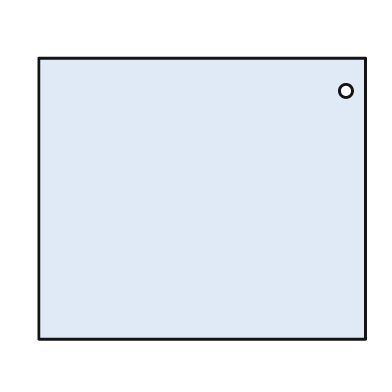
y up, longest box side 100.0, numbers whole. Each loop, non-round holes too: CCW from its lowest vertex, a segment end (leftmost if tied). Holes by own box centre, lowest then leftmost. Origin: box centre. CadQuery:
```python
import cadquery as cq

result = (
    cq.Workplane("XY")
    .moveTo(-50.0, -43.0)
    .lineTo(50.0, -43.0)
    .lineTo(50.0, 43.0)
    .lineTo(-50.0, 43.0)
    .close()
    .moveTo(44.0, 33.0)
    .circle(2.0)
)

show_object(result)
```